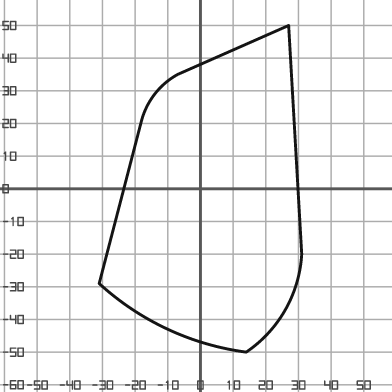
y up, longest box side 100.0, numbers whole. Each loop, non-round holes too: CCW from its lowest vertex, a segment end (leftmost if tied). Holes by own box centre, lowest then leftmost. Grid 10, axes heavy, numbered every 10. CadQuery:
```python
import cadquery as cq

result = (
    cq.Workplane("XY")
    .moveTo(14.0, -50.0)
    .threePointArc((26.0, -37.0), (31.0, -20.0))
    .lineTo(27.0, 50.0)
    .lineTo(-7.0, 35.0)
    .threePointArc((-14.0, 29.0), (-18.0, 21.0))
    .lineTo(-31.0, -29.0)
    .threePointArc((-10.0, -43.0), (14.0, -50.0))
    .close()
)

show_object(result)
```